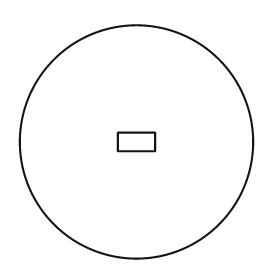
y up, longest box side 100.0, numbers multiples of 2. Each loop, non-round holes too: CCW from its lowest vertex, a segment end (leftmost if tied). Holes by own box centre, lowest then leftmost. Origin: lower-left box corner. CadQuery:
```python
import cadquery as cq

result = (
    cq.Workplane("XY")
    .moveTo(50.0, 50.0)
    .circle(50.0)
    .moveTo(42.0, 46.0)
    .lineTo(58.0, 46.0)
    .lineTo(58.0, 54.0)
    .lineTo(42.0, 54.0)
    .close()
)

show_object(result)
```